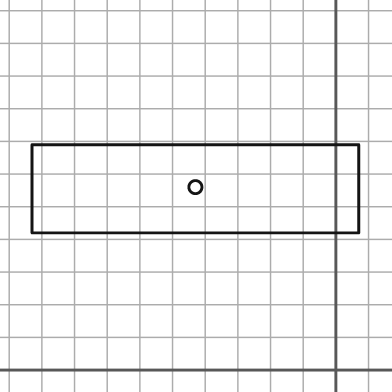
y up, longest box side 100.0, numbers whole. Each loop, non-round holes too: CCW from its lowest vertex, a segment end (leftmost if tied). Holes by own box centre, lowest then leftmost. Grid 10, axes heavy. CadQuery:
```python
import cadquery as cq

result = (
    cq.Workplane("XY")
    .moveTo(-93.0, 42.0)
    .lineTo(7.0, 42.0)
    .lineTo(7.0, 69.0)
    .lineTo(-93.0, 69.0)
    .close()
    .moveTo(-43.0, 56.0)
    .circle(2.0)
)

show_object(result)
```